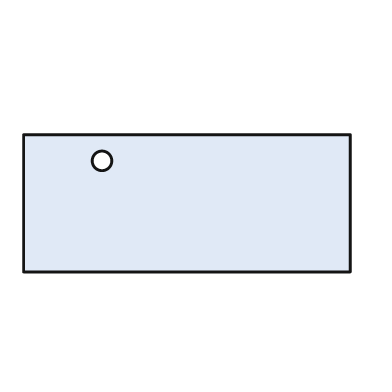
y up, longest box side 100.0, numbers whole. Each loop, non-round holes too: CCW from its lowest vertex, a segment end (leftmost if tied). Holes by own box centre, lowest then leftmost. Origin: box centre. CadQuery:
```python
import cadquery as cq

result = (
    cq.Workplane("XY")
    .moveTo(-50.0, -21.0)
    .lineTo(50.0, -21.0)
    .lineTo(50.0, 21.0)
    .lineTo(-50.0, 21.0)
    .close()
    .moveTo(-26.0, 13.0)
    .circle(3.0)
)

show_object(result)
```